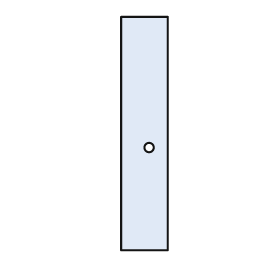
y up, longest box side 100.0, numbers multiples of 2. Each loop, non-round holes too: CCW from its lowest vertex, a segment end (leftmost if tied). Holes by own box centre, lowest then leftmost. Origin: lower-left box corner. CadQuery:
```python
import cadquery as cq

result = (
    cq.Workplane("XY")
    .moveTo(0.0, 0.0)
    .lineTo(20.0, 0.0)
    .lineTo(20.0, 100.0)
    .lineTo(0.0, 100.0)
    .close()
    .moveTo(12.0, 44.0)
    .circle(2.0)
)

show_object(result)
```